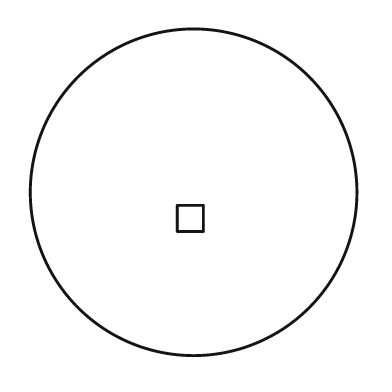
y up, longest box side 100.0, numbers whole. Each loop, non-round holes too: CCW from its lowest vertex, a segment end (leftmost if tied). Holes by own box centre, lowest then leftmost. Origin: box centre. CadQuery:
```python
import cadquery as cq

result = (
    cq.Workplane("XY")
    .moveTo(0.0, 0.0)
    .circle(50.0)
    .moveTo(-5.0, -12.0)
    .lineTo(3.0, -12.0)
    .lineTo(3.0, -4.0)
    .lineTo(-5.0, -4.0)
    .close()
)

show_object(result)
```